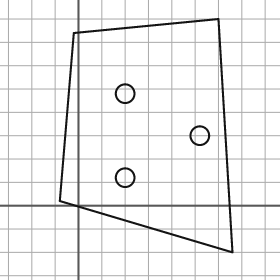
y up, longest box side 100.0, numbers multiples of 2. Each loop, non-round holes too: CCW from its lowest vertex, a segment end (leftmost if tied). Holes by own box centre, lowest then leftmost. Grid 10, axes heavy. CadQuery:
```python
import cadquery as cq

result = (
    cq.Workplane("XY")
    .moveTo(66.0, -20.0)
    .lineTo(60.0, 80.0)
    .lineTo(-2.0, 74.0)
    .lineTo(-8.0, 2.0)
    .close()
    .moveTo(20.0, 12.0)
    .circle(4.0)
    .moveTo(52.0, 30.0)
    .circle(4.0)
    .moveTo(20.0, 48.0)
    .circle(4.0)
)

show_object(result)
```